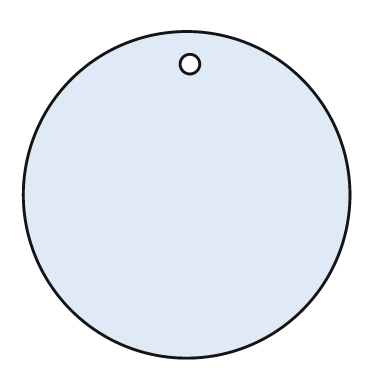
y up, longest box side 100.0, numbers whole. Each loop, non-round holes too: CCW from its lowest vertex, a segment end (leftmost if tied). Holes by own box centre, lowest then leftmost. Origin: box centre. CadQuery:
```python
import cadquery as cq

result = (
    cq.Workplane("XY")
    .moveTo(0.0, 0.0)
    .circle(50.0)
    .moveTo(1.0, 40.0)
    .circle(3.0)
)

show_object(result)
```